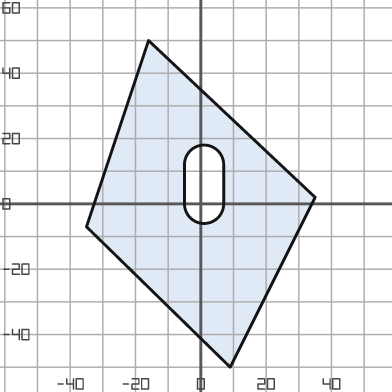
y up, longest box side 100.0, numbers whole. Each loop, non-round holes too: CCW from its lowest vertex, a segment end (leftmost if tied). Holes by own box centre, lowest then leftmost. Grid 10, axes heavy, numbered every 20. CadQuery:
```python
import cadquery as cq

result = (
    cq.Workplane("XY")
    .moveTo(9.0, -50.0)
    .lineTo(35.0, 2.0)
    .lineTo(-16.0, 50.0)
    .lineTo(-35.0, -7.0)
    .close()
    .moveTo(-5.0, 0.0)
    .threePointArc((1.0, -6.0), (7.0, 0.0))
    .lineTo(7.0, 12.0)
    .threePointArc((1.0, 18.0), (-5.0, 12.0))
    .close()
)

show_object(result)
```